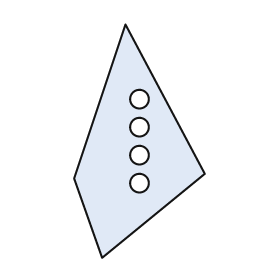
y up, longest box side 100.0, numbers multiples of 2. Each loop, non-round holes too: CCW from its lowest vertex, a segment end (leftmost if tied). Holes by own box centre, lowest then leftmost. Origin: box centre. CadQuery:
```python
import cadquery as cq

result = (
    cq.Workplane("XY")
    .moveTo(-16.0, -50.0)
    .lineTo(28.0, -14.0)
    .lineTo(-6.0, 50.0)
    .lineTo(-28.0, -16.0)
    .close()
    .moveTo(0.0, -18.0)
    .circle(4.0)
    .moveTo(0.0, -6.0)
    .circle(4.0)
    .moveTo(0.0, 6.0)
    .circle(4.0)
    .moveTo(0.0, 18.0)
    .circle(4.0)
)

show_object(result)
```